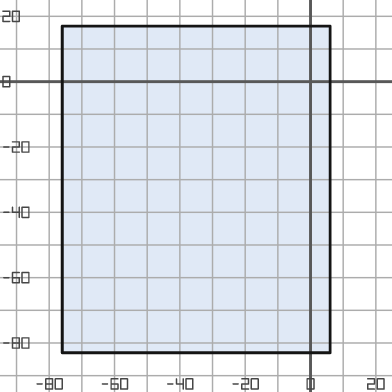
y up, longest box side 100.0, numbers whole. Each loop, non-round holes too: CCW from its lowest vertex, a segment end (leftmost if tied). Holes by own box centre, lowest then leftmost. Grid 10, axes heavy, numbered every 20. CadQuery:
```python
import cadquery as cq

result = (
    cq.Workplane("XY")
    .moveTo(-76.0, -83.0)
    .lineTo(6.0, -83.0)
    .lineTo(6.0, 17.0)
    .lineTo(-76.0, 17.0)
    .close()
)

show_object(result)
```